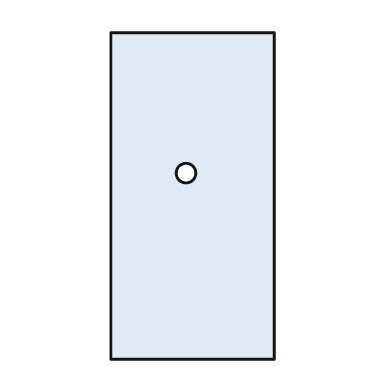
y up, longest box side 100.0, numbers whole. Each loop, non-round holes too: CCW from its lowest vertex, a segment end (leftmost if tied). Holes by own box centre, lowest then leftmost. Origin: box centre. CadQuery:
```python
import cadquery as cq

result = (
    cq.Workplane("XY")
    .moveTo(-25.0, -50.0)
    .lineTo(25.0, -50.0)
    .lineTo(25.0, 50.0)
    .lineTo(-25.0, 50.0)
    .close()
    .moveTo(-2.0, 7.0)
    .circle(3.0)
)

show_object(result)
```